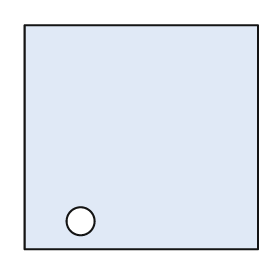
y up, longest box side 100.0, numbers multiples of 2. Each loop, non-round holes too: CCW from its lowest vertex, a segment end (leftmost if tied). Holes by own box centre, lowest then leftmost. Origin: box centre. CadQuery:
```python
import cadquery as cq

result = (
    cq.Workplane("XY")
    .moveTo(-50.0, -48.0)
    .lineTo(50.0, -48.0)
    .lineTo(50.0, 48.0)
    .lineTo(-50.0, 48.0)
    .close()
    .moveTo(-26.0, -36.0)
    .circle(6.0)
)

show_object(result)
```